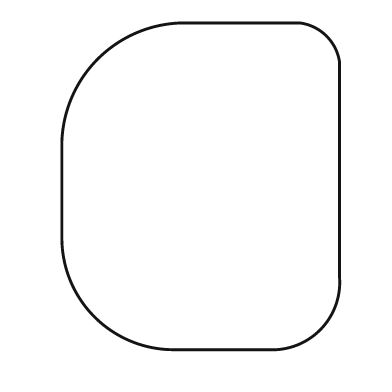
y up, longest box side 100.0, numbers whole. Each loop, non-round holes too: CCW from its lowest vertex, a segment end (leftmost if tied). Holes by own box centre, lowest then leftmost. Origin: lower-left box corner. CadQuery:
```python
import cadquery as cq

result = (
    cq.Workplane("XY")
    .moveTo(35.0, 0.0)
    .lineTo(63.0, 0.0)
    .threePointArc((79.0, 6.0), (85.0, 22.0))
    .lineTo(85.0, 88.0)
    .threePointArc((81.0, 96.0), (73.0, 100.0))
    .lineTo(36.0, 100.0)
    .threePointArc((11.0, 89.0), (0.0, 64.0))
    .lineTo(0.0, 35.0)
    .threePointArc((10.0, 10.0), (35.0, 0.0))
    .close()
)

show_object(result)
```